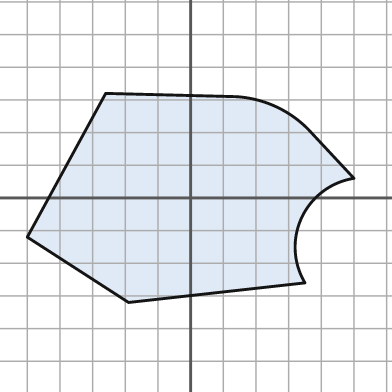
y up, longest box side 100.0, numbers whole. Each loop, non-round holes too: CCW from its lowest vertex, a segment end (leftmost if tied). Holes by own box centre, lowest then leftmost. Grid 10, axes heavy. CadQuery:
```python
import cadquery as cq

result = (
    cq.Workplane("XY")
    .moveTo(-19.0, -32.0)
    .lineTo(35.0, -26.0)
    .threePointArc((34.0, -6.0), (50.0, 6.0))
    .lineTo(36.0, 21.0)
    .threePointArc((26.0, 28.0), (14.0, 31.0))
    .lineTo(-26.0, 32.0)
    .lineTo(-50.0, -12.0)
    .close()
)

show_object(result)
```